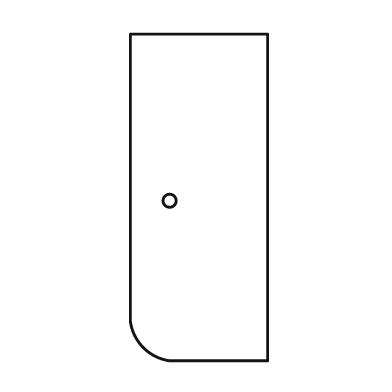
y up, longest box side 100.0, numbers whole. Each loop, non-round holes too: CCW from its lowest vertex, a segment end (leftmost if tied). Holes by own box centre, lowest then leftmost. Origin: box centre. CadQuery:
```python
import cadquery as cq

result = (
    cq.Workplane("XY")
    .moveTo(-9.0, -50.0)
    .lineTo(21.0, -50.0)
    .lineTo(21.0, 50.0)
    .lineTo(-21.0, 50.0)
    .lineTo(-21.0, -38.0)
    .threePointArc((-17.0, -46.0), (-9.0, -50.0))
    .close()
    .moveTo(-9.0, -1.0)
    .circle(2.0)
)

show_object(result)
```